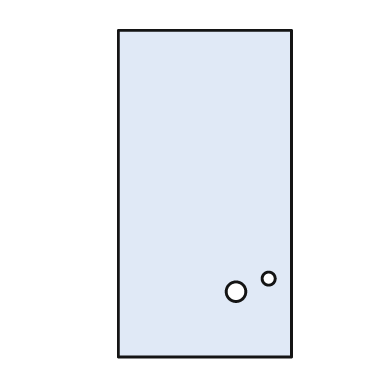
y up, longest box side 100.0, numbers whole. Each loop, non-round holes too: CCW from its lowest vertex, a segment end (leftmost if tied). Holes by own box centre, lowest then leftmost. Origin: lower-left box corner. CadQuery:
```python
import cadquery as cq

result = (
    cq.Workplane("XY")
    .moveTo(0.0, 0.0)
    .lineTo(53.0, 0.0)
    .lineTo(53.0, 100.0)
    .lineTo(0.0, 100.0)
    .close()
    .moveTo(36.0, 20.0)
    .circle(3.0)
    .moveTo(46.0, 24.0)
    .circle(2.0)
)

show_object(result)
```